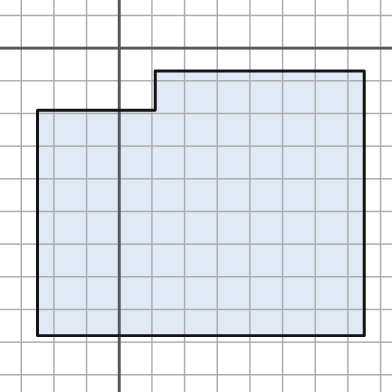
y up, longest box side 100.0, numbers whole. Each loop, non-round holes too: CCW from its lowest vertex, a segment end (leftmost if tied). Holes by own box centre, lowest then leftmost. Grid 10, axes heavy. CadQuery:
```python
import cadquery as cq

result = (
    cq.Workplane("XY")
    .moveTo(-25.0, -88.0)
    .lineTo(75.0, -88.0)
    .lineTo(75.0, -7.0)
    .lineTo(11.0, -7.0)
    .lineTo(11.0, -19.0)
    .lineTo(-25.0, -19.0)
    .close()
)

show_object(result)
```